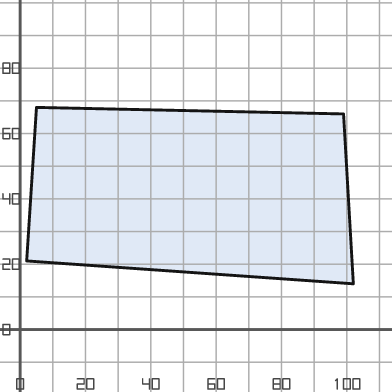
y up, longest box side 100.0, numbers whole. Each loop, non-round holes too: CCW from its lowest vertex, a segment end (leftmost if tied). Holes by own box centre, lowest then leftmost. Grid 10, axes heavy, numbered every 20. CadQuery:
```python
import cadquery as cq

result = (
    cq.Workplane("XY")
    .moveTo(102.0, 14.0)
    .lineTo(99.0, 66.0)
    .lineTo(5.0, 68.0)
    .lineTo(2.0, 21.0)
    .close()
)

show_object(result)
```